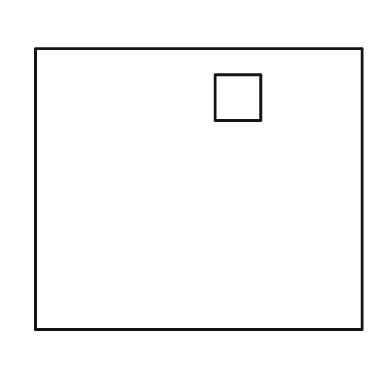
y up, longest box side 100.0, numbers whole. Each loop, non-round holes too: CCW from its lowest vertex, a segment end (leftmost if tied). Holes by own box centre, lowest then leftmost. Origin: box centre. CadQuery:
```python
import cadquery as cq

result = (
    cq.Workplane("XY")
    .moveTo(-50.0, -43.0)
    .lineTo(50.0, -43.0)
    .lineTo(50.0, 43.0)
    .lineTo(-50.0, 43.0)
    .close()
    .moveTo(5.0, 21.0)
    .lineTo(19.0, 21.0)
    .lineTo(19.0, 35.0)
    .lineTo(5.0, 35.0)
    .close()
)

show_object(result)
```